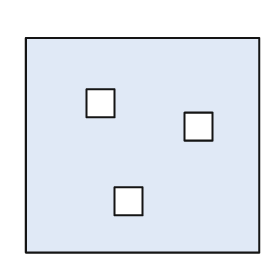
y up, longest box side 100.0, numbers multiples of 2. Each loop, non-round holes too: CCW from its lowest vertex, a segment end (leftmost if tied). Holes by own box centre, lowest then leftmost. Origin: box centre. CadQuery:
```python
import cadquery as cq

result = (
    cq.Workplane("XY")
    .moveTo(-50.0, -46.0)
    .lineTo(50.0, -46.0)
    .lineTo(50.0, 46.0)
    .lineTo(-50.0, 46.0)
    .close()
    .moveTo(-12.0, -30.0)
    .lineTo(0.0, -30.0)
    .lineTo(0.0, -18.0)
    .lineTo(-12.0, -18.0)
    .close()
    .moveTo(18.0, 2.0)
    .lineTo(30.0, 2.0)
    .lineTo(30.0, 14.0)
    .lineTo(18.0, 14.0)
    .close()
    .moveTo(-24.0, 12.0)
    .lineTo(-12.0, 12.0)
    .lineTo(-12.0, 24.0)
    .lineTo(-24.0, 24.0)
    .close()
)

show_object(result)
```